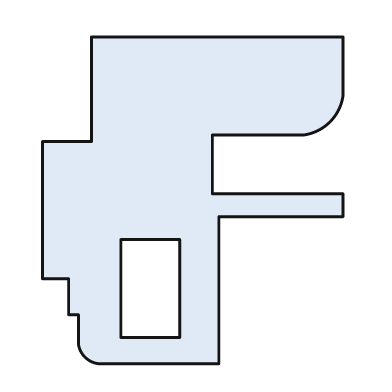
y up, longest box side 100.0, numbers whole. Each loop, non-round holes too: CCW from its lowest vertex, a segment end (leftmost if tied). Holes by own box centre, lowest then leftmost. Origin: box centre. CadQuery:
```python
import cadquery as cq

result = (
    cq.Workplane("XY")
    .moveTo(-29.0, -50.0)
    .lineTo(8.0, -50.0)
    .lineTo(8.0, -5.0)
    .lineTo(46.0, -5.0)
    .lineTo(46.0, 2.0)
    .lineTo(6.0, 2.0)
    .lineTo(6.0, 20.0)
    .lineTo(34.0, 20.0)
    .threePointArc((42.0, 24.0), (46.0, 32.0))
    .lineTo(46.0, 50.0)
    .lineTo(-31.0, 50.0)
    .lineTo(-31.0, 18.0)
    .lineTo(-46.0, 18.0)
    .lineTo(-46.0, -24.0)
    .lineTo(-38.0, -24.0)
    .lineTo(-38.0, -35.0)
    .lineTo(-35.0, -35.0)
    .lineTo(-35.0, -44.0)
    .threePointArc((-33.0, -48.0), (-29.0, -50.0))
    .close()
    .moveTo(-22.0, -42.0)
    .lineTo(-4.0, -42.0)
    .lineTo(-4.0, -12.0)
    .lineTo(-22.0, -12.0)
    .close()
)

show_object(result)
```